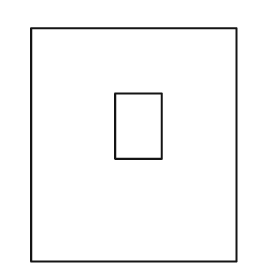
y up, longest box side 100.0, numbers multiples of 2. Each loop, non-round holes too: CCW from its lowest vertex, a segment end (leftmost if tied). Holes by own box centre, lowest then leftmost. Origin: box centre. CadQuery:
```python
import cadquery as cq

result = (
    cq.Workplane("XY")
    .moveTo(-44.0, -50.0)
    .lineTo(44.0, -50.0)
    .lineTo(44.0, 50.0)
    .lineTo(-44.0, 50.0)
    .close()
    .moveTo(-8.0, -6.0)
    .lineTo(12.0, -6.0)
    .lineTo(12.0, 22.0)
    .lineTo(-8.0, 22.0)
    .close()
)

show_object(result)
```